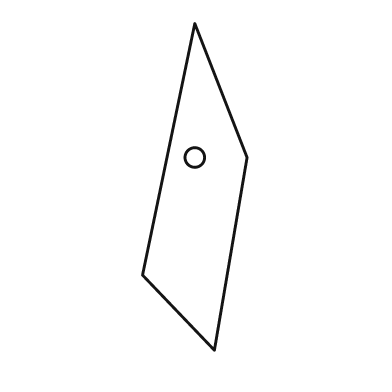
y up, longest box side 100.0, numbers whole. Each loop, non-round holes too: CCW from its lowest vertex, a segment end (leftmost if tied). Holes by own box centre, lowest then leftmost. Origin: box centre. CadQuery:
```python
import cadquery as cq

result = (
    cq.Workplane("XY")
    .moveTo(6.0, -50.0)
    .lineTo(16.0, 9.0)
    .lineTo(0.0, 50.0)
    .lineTo(-16.0, -27.0)
    .close()
    .moveTo(0.0, 9.0)
    .circle(3.0)
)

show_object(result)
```